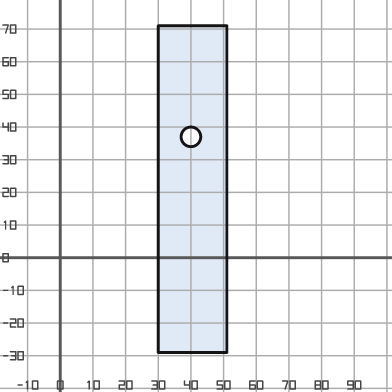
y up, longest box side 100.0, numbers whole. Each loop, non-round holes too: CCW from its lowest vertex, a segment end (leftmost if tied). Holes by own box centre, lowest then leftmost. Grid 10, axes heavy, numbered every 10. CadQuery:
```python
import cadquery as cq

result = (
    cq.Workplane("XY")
    .moveTo(30.0, -29.0)
    .lineTo(51.0, -29.0)
    .lineTo(51.0, 71.0)
    .lineTo(30.0, 71.0)
    .close()
    .moveTo(40.0, 37.0)
    .circle(3.0)
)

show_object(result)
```